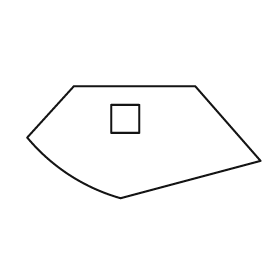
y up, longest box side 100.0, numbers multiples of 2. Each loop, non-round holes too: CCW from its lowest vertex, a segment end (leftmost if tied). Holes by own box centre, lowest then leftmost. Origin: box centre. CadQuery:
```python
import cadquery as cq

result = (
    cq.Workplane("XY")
    .moveTo(-10.0, -24.0)
    .lineTo(50.0, -8.0)
    .lineTo(22.0, 24.0)
    .lineTo(-30.0, 24.0)
    .lineTo(-50.0, 2.0)
    .threePointArc((-32.0, -14.0), (-10.0, -24.0))
    .close()
    .moveTo(-14.0, 4.0)
    .lineTo(-2.0, 4.0)
    .lineTo(-2.0, 16.0)
    .lineTo(-14.0, 16.0)
    .close()
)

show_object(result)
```